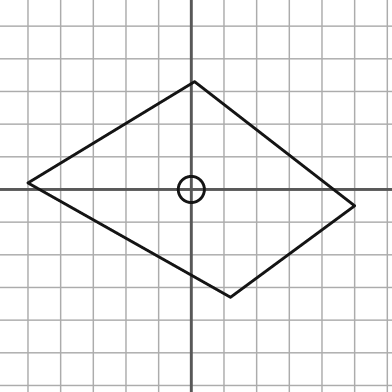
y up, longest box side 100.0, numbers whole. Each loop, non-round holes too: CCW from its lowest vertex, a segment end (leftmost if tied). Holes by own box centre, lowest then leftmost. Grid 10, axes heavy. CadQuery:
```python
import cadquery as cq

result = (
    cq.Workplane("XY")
    .moveTo(12.0, -33.0)
    .lineTo(50.0, -5.0)
    .lineTo(1.0, 33.0)
    .lineTo(-50.0, 2.0)
    .close()
    .moveTo(0.0, 0.0)
    .circle(4.0)
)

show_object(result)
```